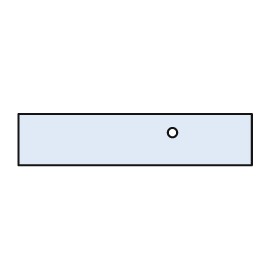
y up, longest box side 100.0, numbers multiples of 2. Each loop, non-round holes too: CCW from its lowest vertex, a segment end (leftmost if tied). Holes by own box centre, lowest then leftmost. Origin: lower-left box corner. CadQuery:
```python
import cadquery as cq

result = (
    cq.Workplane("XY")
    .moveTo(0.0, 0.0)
    .lineTo(100.0, 0.0)
    .lineTo(100.0, 22.0)
    .lineTo(0.0, 22.0)
    .close()
    .moveTo(66.0, 14.0)
    .circle(2.0)
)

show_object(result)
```